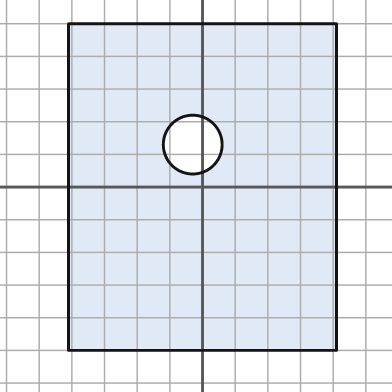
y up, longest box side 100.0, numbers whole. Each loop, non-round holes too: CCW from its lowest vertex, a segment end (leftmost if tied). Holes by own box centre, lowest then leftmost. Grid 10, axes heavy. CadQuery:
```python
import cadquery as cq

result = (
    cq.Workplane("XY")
    .moveTo(-41.0, -50.0)
    .lineTo(41.0, -50.0)
    .lineTo(41.0, 50.0)
    .lineTo(-41.0, 50.0)
    .close()
    .moveTo(-3.0, 13.0)
    .circle(9.0)
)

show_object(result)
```